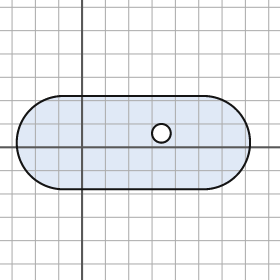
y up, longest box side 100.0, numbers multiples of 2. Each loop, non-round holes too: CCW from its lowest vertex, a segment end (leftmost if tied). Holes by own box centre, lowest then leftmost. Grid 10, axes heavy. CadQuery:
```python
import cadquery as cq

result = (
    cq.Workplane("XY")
    .moveTo(-8.0, -18.0)
    .lineTo(52.0, -18.0)
    .threePointArc((72.0, 2.0), (52.0, 22.0))
    .lineTo(-8.0, 22.0)
    .threePointArc((-28.0, 2.0), (-8.0, -18.0))
    .close()
    .moveTo(34.0, 6.0)
    .circle(4.0)
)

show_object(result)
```